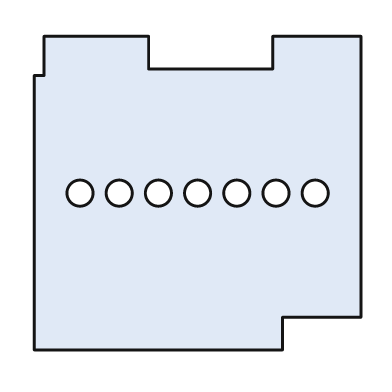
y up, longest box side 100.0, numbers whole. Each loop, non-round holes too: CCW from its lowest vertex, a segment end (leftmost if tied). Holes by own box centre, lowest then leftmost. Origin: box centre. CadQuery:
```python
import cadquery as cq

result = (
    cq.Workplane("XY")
    .moveTo(-50.0, -48.0)
    .lineTo(26.0, -48.0)
    .lineTo(26.0, -38.0)
    .lineTo(50.0, -38.0)
    .lineTo(50.0, 48.0)
    .lineTo(23.0, 48.0)
    .lineTo(23.0, 38.0)
    .lineTo(-15.0, 38.0)
    .lineTo(-15.0, 48.0)
    .lineTo(-47.0, 48.0)
    .lineTo(-47.0, 36.0)
    .lineTo(-50.0, 36.0)
    .close()
    .moveTo(-36.0, 0.0)
    .circle(4.0)
    .moveTo(-24.0, 0.0)
    .circle(4.0)
    .moveTo(-12.0, 0.0)
    .circle(4.0)
    .moveTo(0.0, 0.0)
    .circle(4.0)
    .moveTo(12.0, 0.0)
    .circle(4.0)
    .moveTo(24.0, 0.0)
    .circle(4.0)
    .moveTo(36.0, 0.0)
    .circle(4.0)
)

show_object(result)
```